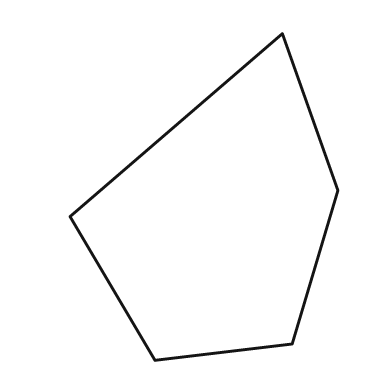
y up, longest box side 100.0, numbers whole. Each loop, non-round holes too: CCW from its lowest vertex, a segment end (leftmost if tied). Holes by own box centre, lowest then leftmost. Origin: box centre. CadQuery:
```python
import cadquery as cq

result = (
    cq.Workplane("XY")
    .moveTo(-15.0, -50.0)
    .lineTo(27.0, -45.0)
    .lineTo(41.0, 2.0)
    .lineTo(24.0, 50.0)
    .lineTo(-41.0, -6.0)
    .close()
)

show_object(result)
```